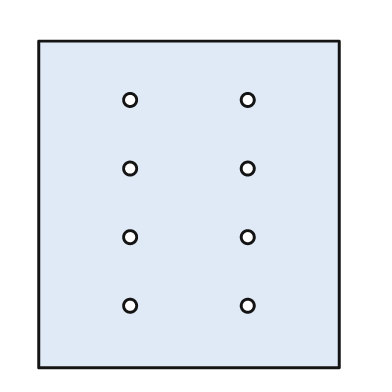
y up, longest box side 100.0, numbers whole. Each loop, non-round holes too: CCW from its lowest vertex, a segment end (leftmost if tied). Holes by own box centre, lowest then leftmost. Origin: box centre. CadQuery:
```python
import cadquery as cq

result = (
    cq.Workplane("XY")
    .moveTo(-46.0, -50.0)
    .lineTo(46.0, -50.0)
    .lineTo(46.0, 50.0)
    .lineTo(-46.0, 50.0)
    .close()
    .moveTo(-18.0, -31.0)
    .circle(2.0)
    .moveTo(18.0, -31.0)
    .circle(2.0)
    .moveTo(-18.0, -10.0)
    .circle(2.0)
    .moveTo(18.0, -10.0)
    .circle(2.0)
    .moveTo(-18.0, 11.0)
    .circle(2.0)
    .moveTo(18.0, 11.0)
    .circle(2.0)
    .moveTo(-18.0, 32.0)
    .circle(2.0)
    .moveTo(18.0, 32.0)
    .circle(2.0)
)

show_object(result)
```